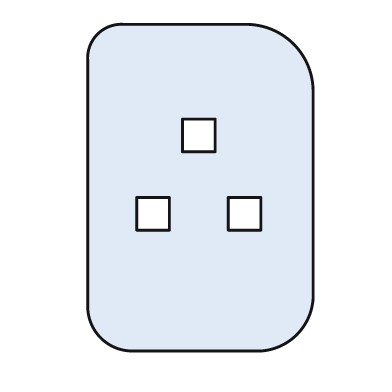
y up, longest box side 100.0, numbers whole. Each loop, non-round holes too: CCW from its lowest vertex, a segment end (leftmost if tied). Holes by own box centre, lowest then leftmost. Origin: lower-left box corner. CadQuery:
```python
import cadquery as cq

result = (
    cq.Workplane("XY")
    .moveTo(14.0, 0.0)
    .lineTo(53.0, 0.0)
    .threePointArc((64.0, 5.0), (69.0, 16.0))
    .lineTo(69.0, 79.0)
    .threePointArc((63.0, 94.0), (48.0, 100.0))
    .lineTo(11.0, 100.0)
    .threePointArc((3.0, 97.0), (0.0, 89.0))
    .lineTo(0.0, 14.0)
    .threePointArc((4.0, 4.0), (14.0, 0.0))
    .close()
    .moveTo(15.0, 37.0)
    .lineTo(25.0, 37.0)
    .lineTo(25.0, 47.0)
    .lineTo(15.0, 47.0)
    .close()
    .moveTo(43.0, 37.0)
    .lineTo(53.0, 37.0)
    .lineTo(53.0, 47.0)
    .lineTo(43.0, 47.0)
    .close()
    .moveTo(29.0, 61.0)
    .lineTo(39.0, 61.0)
    .lineTo(39.0, 71.0)
    .lineTo(29.0, 71.0)
    .close()
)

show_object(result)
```